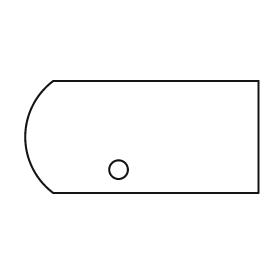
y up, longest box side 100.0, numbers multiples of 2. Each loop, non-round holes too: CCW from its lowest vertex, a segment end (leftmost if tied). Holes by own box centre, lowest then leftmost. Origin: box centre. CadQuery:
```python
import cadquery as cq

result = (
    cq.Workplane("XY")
    .moveTo(-38.0, -24.0)
    .lineTo(50.0, -24.0)
    .lineTo(50.0, 24.0)
    .lineTo(-38.0, 24.0)
    .threePointArc((-50.0, 0.0), (-38.0, -24.0))
    .close()
    .moveTo(-10.0, -14.0)
    .circle(4.0)
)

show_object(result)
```